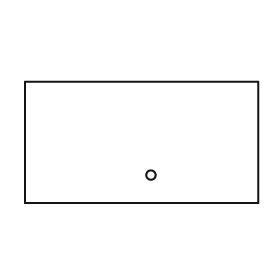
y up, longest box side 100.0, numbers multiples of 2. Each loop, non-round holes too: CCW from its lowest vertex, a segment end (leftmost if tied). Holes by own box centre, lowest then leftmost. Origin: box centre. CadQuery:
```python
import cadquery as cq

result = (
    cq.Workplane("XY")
    .moveTo(-50.0, -26.0)
    .lineTo(50.0, -26.0)
    .lineTo(50.0, 26.0)
    .lineTo(-50.0, 26.0)
    .close()
    .moveTo(4.0, -14.0)
    .circle(2.0)
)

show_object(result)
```